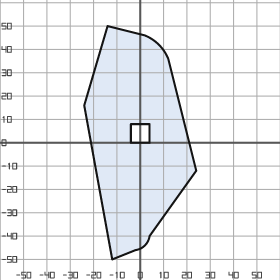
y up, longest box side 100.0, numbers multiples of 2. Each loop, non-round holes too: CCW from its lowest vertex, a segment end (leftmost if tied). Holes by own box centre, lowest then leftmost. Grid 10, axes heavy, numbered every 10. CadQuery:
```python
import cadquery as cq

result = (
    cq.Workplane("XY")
    .moveTo(-12.0, -50.0)
    .lineTo(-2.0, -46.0)
    .threePointArc((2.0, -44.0), (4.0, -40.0))
    .lineTo(24.0, -12.0)
    .lineTo(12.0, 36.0)
    .threePointArc((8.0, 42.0), (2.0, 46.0))
    .lineTo(-14.0, 50.0)
    .lineTo(-24.0, 16.0)
    .close()
    .moveTo(-4.0, 0.0)
    .lineTo(4.0, 0.0)
    .lineTo(4.0, 8.0)
    .lineTo(-4.0, 8.0)
    .close()
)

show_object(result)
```